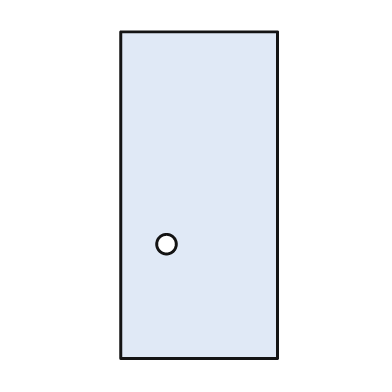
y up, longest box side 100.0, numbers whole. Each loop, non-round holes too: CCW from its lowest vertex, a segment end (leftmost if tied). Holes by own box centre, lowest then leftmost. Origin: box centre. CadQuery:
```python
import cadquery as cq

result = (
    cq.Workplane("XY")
    .moveTo(-24.0, -50.0)
    .lineTo(24.0, -50.0)
    .lineTo(24.0, 50.0)
    .lineTo(-24.0, 50.0)
    .close()
    .moveTo(-10.0, -15.0)
    .circle(3.0)
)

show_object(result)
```